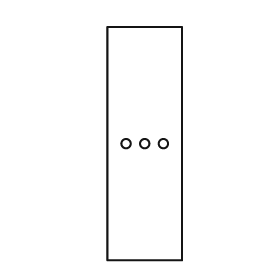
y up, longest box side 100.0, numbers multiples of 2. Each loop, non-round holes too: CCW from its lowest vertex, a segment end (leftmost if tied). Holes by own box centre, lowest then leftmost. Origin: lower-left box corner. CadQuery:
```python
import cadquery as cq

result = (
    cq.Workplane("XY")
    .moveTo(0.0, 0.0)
    .lineTo(32.0, 0.0)
    .lineTo(32.0, 100.0)
    .lineTo(0.0, 100.0)
    .close()
    .moveTo(8.0, 50.0)
    .circle(2.0)
    .moveTo(16.0, 50.0)
    .circle(2.0)
    .moveTo(24.0, 50.0)
    .circle(2.0)
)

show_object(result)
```